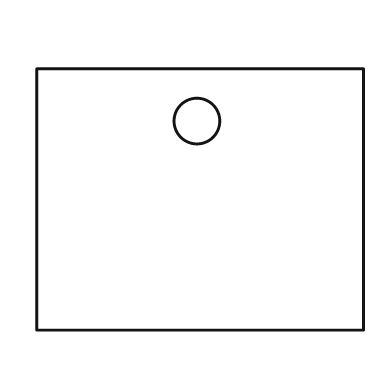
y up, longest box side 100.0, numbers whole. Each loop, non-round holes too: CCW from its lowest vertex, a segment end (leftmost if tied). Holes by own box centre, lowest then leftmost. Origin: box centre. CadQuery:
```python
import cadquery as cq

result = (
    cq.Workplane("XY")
    .moveTo(-50.0, -40.0)
    .lineTo(50.0, -40.0)
    .lineTo(50.0, 40.0)
    .lineTo(-50.0, 40.0)
    .close()
    .moveTo(-1.0, 24.0)
    .circle(7.0)
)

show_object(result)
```